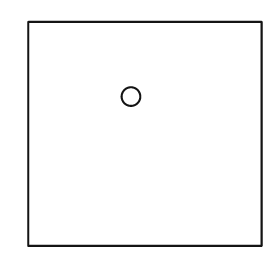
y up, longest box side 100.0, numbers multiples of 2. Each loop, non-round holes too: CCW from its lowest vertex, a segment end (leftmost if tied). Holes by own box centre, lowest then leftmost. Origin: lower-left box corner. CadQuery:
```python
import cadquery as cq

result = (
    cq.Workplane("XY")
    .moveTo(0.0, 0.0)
    .lineTo(100.0, 0.0)
    .lineTo(100.0, 96.0)
    .lineTo(0.0, 96.0)
    .close()
    .moveTo(44.0, 64.0)
    .circle(4.0)
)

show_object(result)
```